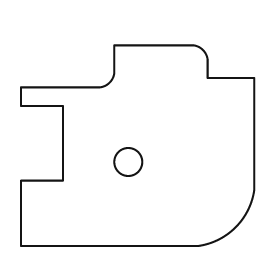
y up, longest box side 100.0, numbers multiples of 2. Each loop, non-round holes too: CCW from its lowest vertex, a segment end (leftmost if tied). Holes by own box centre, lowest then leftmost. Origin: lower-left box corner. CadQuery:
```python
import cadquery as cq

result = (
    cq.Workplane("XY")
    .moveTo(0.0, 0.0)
    .lineTo(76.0, 0.0)
    .threePointArc((92.0, 8.0), (100.0, 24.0))
    .lineTo(100.0, 72.0)
    .lineTo(80.0, 72.0)
    .lineTo(80.0, 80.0)
    .threePointArc((78.0, 84.0), (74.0, 86.0))
    .lineTo(40.0, 86.0)
    .lineTo(40.0, 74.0)
    .threePointArc((38.0, 70.0), (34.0, 68.0))
    .lineTo(0.0, 68.0)
    .lineTo(0.0, 60.0)
    .lineTo(18.0, 60.0)
    .lineTo(18.0, 28.0)
    .lineTo(0.0, 28.0)
    .close()
    .moveTo(46.0, 36.0)
    .circle(6.0)
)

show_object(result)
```